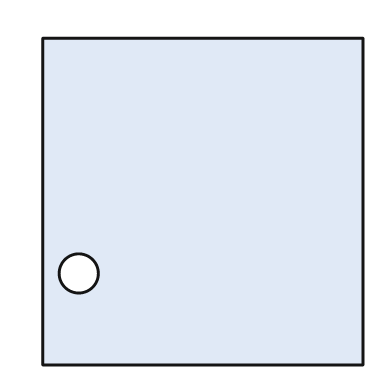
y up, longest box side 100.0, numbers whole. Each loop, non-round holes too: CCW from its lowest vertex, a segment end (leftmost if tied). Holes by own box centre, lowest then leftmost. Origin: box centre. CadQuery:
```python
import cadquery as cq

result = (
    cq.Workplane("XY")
    .moveTo(-49.0, -50.0)
    .lineTo(49.0, -50.0)
    .lineTo(49.0, 50.0)
    .lineTo(-49.0, 50.0)
    .close()
    .moveTo(-38.0, -22.0)
    .circle(6.0)
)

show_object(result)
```